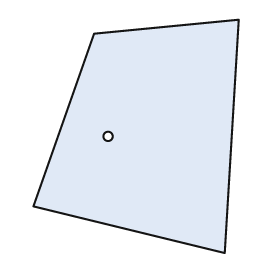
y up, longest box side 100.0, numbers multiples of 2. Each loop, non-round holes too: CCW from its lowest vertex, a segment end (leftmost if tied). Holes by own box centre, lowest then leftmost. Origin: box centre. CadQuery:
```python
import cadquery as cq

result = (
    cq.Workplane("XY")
    .moveTo(38.0, -50.0)
    .lineTo(44.0, 50.0)
    .lineTo(-18.0, 44.0)
    .lineTo(-44.0, -30.0)
    .close()
    .moveTo(-12.0, 0.0)
    .circle(2.0)
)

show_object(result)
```